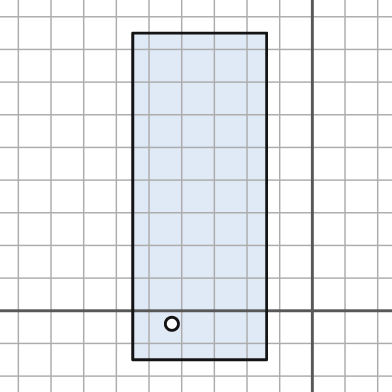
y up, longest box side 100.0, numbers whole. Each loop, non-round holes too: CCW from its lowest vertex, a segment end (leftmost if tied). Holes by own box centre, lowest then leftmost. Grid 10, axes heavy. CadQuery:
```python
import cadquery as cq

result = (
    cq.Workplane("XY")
    .moveTo(-55.0, -15.0)
    .lineTo(-14.0, -15.0)
    .lineTo(-14.0, 85.0)
    .lineTo(-55.0, 85.0)
    .close()
    .moveTo(-43.0, -4.0)
    .circle(2.0)
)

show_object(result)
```